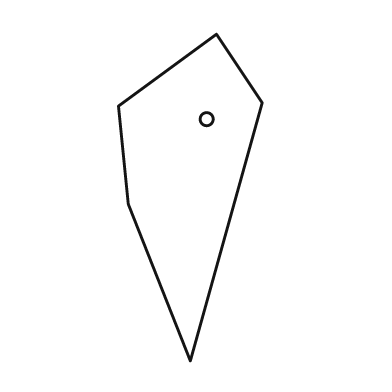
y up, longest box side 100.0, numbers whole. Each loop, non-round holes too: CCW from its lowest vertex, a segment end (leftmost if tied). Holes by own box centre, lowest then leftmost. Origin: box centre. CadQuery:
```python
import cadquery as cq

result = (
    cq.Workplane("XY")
    .moveTo(0.0, -50.0)
    .lineTo(22.0, 29.0)
    .lineTo(8.0, 50.0)
    .lineTo(-22.0, 28.0)
    .lineTo(-19.0, -2.0)
    .close()
    .moveTo(5.0, 24.0)
    .circle(2.0)
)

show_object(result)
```